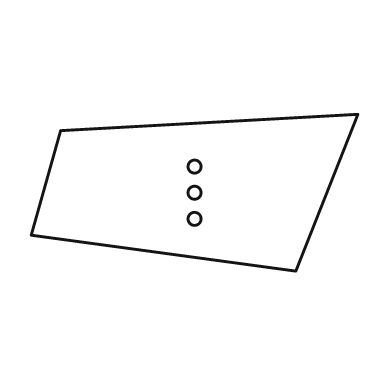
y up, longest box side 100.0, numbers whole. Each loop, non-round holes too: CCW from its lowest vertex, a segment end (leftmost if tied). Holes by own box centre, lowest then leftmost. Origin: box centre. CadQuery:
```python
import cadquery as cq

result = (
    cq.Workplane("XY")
    .moveTo(31.0, -24.0)
    .lineTo(50.0, 24.0)
    .lineTo(-41.0, 19.0)
    .lineTo(-50.0, -13.0)
    .close()
    .moveTo(0.0, -8.0)
    .circle(2.0)
    .moveTo(0.0, 0.0)
    .circle(2.0)
    .moveTo(0.0, 8.0)
    .circle(2.0)
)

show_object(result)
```